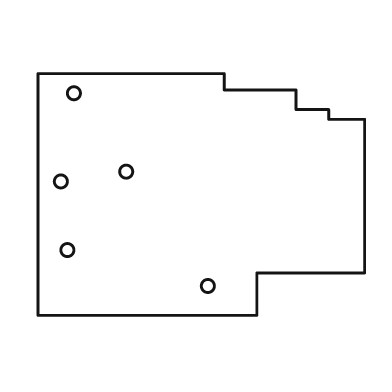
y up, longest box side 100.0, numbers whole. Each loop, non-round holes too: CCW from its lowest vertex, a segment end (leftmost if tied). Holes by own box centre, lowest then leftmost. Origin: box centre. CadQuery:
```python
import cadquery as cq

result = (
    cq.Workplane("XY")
    .moveTo(-50.0, -37.0)
    .lineTo(17.0, -37.0)
    .lineTo(17.0, -24.0)
    .lineTo(50.0, -24.0)
    .lineTo(50.0, 23.0)
    .lineTo(39.0, 23.0)
    .lineTo(39.0, 26.0)
    .lineTo(29.0, 26.0)
    .lineTo(29.0, 32.0)
    .lineTo(7.0, 32.0)
    .lineTo(7.0, 37.0)
    .lineTo(-50.0, 37.0)
    .close()
    .moveTo(2.0, -28.0)
    .circle(2.0)
    .moveTo(-41.0, -17.0)
    .circle(2.0)
    .moveTo(-43.0, 4.0)
    .circle(2.0)
    .moveTo(-23.0, 7.0)
    .circle(2.0)
    .moveTo(-39.0, 31.0)
    .circle(2.0)
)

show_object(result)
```